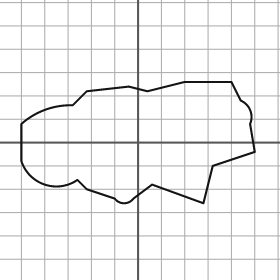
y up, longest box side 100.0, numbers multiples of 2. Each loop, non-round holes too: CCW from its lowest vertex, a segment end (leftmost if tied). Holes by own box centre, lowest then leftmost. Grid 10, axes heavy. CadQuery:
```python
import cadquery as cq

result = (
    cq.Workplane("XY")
    .moveTo(28.0, -26.0)
    .lineTo(32.0, -10.0)
    .lineTo(50.0, -4.0)
    .lineTo(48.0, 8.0)
    .threePointArc((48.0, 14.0), (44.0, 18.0))
    .lineTo(40.0, 26.0)
    .lineTo(20.0, 26.0)
    .lineTo(4.0, 22.0)
    .lineTo(-4.0, 24.0)
    .lineTo(-22.0, 22.0)
    .lineTo(-28.0, 16.0)
    .threePointArc((-40.0, 14.0), (-50.0, 8.0))
    .lineTo(-50.0, -8.0)
    .threePointArc((-40.0, -18.0), (-26.0, -16.0))
    .lineTo(-22.0, -20.0)
    .lineTo(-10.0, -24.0)
    .threePointArc((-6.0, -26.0), (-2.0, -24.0))
    .lineTo(6.0, -18.0)
    .close()
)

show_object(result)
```